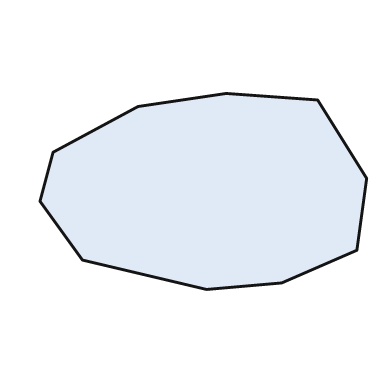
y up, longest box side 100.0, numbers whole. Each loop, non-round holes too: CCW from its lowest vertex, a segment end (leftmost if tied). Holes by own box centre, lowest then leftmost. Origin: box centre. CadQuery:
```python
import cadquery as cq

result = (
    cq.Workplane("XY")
    .moveTo(1.0, -30.0)
    .lineTo(24.0, -28.0)
    .lineTo(47.0, -18.0)
    .lineTo(50.0, 4.0)
    .lineTo(35.0, 28.0)
    .lineTo(7.0, 30.0)
    .lineTo(-20.0, 26.0)
    .lineTo(-46.0, 12.0)
    .lineTo(-50.0, -3.0)
    .lineTo(-37.0, -21.0)
    .close()
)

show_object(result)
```